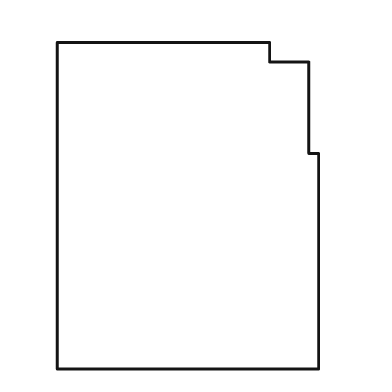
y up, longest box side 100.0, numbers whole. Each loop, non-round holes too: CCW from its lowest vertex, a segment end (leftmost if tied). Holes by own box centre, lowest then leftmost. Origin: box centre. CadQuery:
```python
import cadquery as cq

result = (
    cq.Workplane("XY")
    .moveTo(-40.0, -50.0)
    .lineTo(40.0, -50.0)
    .lineTo(40.0, 16.0)
    .lineTo(37.0, 16.0)
    .lineTo(37.0, 44.0)
    .lineTo(25.0, 44.0)
    .lineTo(25.0, 50.0)
    .lineTo(-40.0, 50.0)
    .close()
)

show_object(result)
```